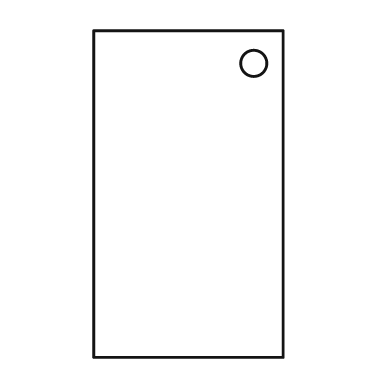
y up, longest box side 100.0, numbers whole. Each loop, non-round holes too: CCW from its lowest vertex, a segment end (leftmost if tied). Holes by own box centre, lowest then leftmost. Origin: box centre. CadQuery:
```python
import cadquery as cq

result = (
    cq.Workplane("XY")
    .moveTo(-29.0, -50.0)
    .lineTo(29.0, -50.0)
    .lineTo(29.0, 50.0)
    .lineTo(-29.0, 50.0)
    .close()
    .moveTo(20.0, 40.0)
    .circle(4.0)
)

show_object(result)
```